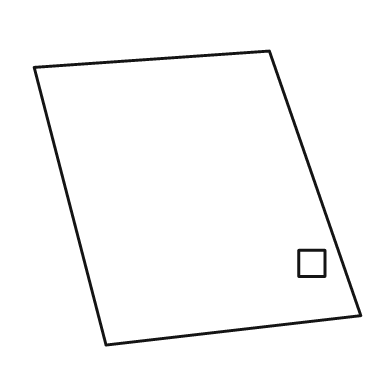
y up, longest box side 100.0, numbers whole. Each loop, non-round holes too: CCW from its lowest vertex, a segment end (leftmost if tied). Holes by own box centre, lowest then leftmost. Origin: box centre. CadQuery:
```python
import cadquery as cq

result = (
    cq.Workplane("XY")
    .moveTo(-28.0, -45.0)
    .lineTo(50.0, -36.0)
    .lineTo(22.0, 45.0)
    .lineTo(-50.0, 40.0)
    .close()
    .moveTo(31.0, -24.0)
    .lineTo(39.0, -24.0)
    .lineTo(39.0, -16.0)
    .lineTo(31.0, -16.0)
    .close()
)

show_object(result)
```